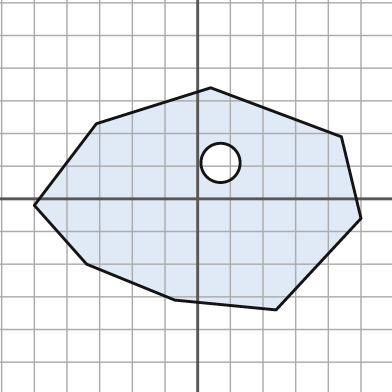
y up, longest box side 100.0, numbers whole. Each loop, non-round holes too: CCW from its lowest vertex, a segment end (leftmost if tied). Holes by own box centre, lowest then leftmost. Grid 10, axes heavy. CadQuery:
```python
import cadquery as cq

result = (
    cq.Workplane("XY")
    .moveTo(24.0, -34.0)
    .lineTo(50.0, -6.0)
    .lineTo(44.0, 19.0)
    .lineTo(4.0, 34.0)
    .lineTo(-31.0, 23.0)
    .lineTo(-50.0, -2.0)
    .lineTo(-34.0, -20.0)
    .lineTo(-7.0, -31.0)
    .close()
    .moveTo(7.0, 11.0)
    .circle(6.0)
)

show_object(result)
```